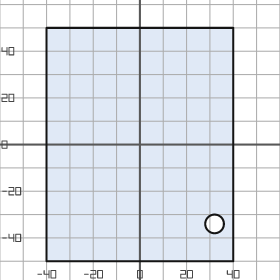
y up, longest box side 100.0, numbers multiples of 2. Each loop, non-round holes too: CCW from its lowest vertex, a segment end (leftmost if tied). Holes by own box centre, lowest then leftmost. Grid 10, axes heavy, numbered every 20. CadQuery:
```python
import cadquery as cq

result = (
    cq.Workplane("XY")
    .moveTo(-40.0, -50.0)
    .lineTo(40.0, -50.0)
    .lineTo(40.0, 50.0)
    .lineTo(-40.0, 50.0)
    .close()
    .moveTo(32.0, -34.0)
    .circle(4.0)
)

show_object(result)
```